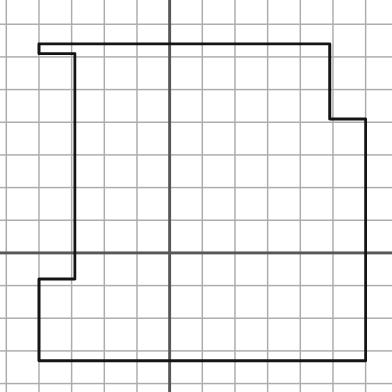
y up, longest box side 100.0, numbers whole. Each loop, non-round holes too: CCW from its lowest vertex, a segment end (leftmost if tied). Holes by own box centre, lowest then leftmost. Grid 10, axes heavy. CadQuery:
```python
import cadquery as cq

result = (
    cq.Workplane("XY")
    .moveTo(-40.0, -33.0)
    .lineTo(60.0, -33.0)
    .lineTo(60.0, 41.0)
    .lineTo(49.0, 41.0)
    .lineTo(49.0, 64.0)
    .lineTo(-40.0, 64.0)
    .lineTo(-40.0, 61.0)
    .lineTo(-29.0, 61.0)
    .lineTo(-29.0, -8.0)
    .lineTo(-40.0, -8.0)
    .close()
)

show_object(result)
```